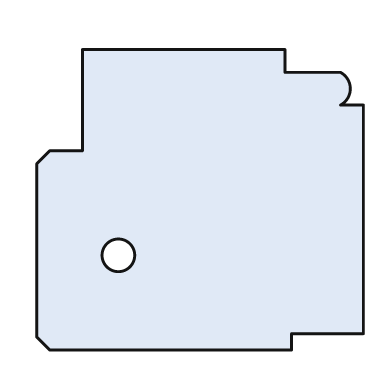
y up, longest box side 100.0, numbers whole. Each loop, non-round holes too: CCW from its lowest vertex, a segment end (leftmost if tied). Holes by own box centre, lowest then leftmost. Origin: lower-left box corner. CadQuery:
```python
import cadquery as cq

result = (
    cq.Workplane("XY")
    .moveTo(4.0, 0.0)
    .lineTo(78.0, 0.0)
    .lineTo(78.0, 5.0)
    .lineTo(100.0, 5.0)
    .lineTo(100.0, 75.0)
    .lineTo(93.0, 75.0)
    .threePointArc((96.0, 80.0), (93.0, 85.0))
    .lineTo(76.0, 85.0)
    .lineTo(76.0, 92.0)
    .lineTo(14.0, 92.0)
    .lineTo(14.0, 61.0)
    .lineTo(4.0, 61.0)
    .lineTo(0.0, 57.0)
    .lineTo(0.0, 4.0)
    .close()
    .moveTo(25.0, 29.0)
    .circle(5.0)
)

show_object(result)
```